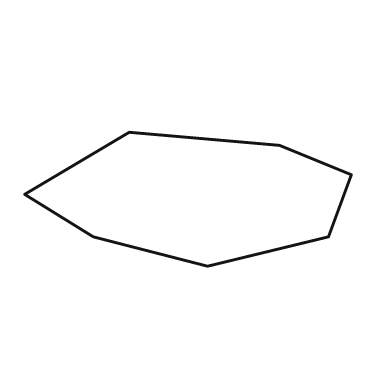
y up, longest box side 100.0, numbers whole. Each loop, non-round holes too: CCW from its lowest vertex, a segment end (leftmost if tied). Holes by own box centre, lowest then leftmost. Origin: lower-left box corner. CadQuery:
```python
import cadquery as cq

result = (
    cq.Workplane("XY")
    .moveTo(56.0, 0.0)
    .lineTo(93.0, 9.0)
    .lineTo(100.0, 28.0)
    .lineTo(78.0, 37.0)
    .lineTo(32.0, 41.0)
    .lineTo(0.0, 22.0)
    .lineTo(21.0, 9.0)
    .close()
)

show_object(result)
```